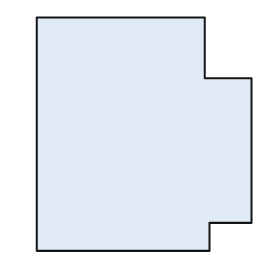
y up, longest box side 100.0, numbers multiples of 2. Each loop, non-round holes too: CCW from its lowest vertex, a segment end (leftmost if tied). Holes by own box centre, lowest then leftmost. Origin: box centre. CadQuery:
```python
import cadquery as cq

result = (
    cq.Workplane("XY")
    .moveTo(-46.0, -50.0)
    .lineTo(28.0, -50.0)
    .lineTo(28.0, -38.0)
    .lineTo(46.0, -38.0)
    .lineTo(46.0, 24.0)
    .lineTo(26.0, 24.0)
    .lineTo(26.0, 50.0)
    .lineTo(-46.0, 50.0)
    .close()
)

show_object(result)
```